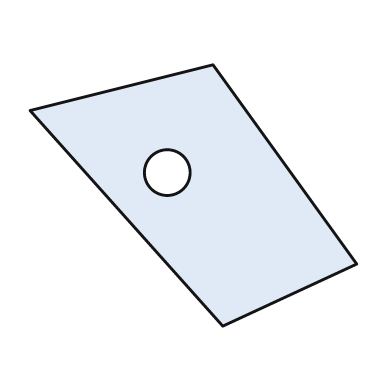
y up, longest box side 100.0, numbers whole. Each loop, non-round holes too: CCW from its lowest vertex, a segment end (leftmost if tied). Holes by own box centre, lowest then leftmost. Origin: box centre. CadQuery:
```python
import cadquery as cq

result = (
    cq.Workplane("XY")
    .moveTo(9.0, -40.0)
    .lineTo(50.0, -21.0)
    .lineTo(6.0, 40.0)
    .lineTo(-50.0, 26.0)
    .close()
    .moveTo(-8.0, 7.0)
    .circle(7.0)
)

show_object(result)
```